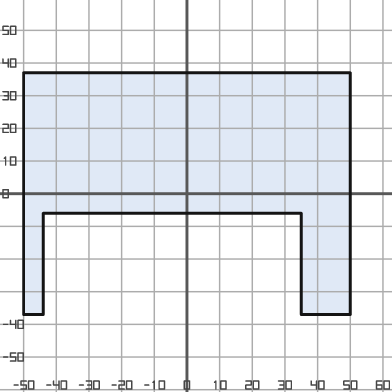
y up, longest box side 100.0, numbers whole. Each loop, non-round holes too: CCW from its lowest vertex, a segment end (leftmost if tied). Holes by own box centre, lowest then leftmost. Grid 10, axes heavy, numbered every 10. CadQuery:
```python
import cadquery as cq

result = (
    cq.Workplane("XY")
    .moveTo(-50.0, -37.0)
    .lineTo(-44.0, -37.0)
    .lineTo(-44.0, -6.0)
    .lineTo(35.0, -6.0)
    .lineTo(35.0, -37.0)
    .lineTo(50.0, -37.0)
    .lineTo(50.0, 37.0)
    .lineTo(-50.0, 37.0)
    .close()
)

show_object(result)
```